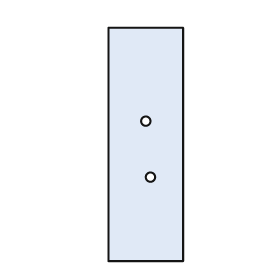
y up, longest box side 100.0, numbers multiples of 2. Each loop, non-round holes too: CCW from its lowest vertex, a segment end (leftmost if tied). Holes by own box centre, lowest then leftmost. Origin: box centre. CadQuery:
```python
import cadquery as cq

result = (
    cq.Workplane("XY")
    .moveTo(-16.0, -50.0)
    .lineTo(16.0, -50.0)
    .lineTo(16.0, 50.0)
    .lineTo(-16.0, 50.0)
    .close()
    .moveTo(2.0, -14.0)
    .circle(2.0)
    .moveTo(0.0, 10.0)
    .circle(2.0)
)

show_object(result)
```